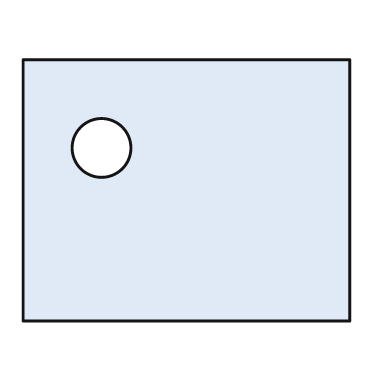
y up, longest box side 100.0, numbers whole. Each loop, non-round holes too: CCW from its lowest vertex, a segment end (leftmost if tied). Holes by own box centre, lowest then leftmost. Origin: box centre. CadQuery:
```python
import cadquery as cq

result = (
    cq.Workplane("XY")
    .moveTo(-50.0, -40.0)
    .lineTo(50.0, -40.0)
    .lineTo(50.0, 40.0)
    .lineTo(-50.0, 40.0)
    .close()
    .moveTo(-26.0, 13.0)
    .circle(9.0)
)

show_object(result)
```